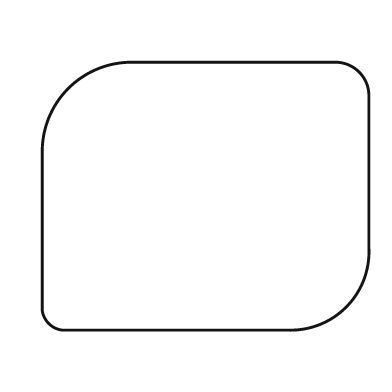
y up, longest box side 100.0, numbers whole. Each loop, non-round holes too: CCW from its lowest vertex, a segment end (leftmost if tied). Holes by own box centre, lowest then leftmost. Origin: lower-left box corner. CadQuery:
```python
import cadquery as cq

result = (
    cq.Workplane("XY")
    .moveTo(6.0, 0.0)
    .lineTo(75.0, 0.0)
    .threePointArc((93.0, 7.0), (100.0, 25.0))
    .lineTo(100.0, 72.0)
    .threePointArc((97.0, 79.0), (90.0, 82.0))
    .lineTo(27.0, 82.0)
    .threePointArc((8.0, 74.0), (0.0, 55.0))
    .lineTo(0.0, 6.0)
    .threePointArc((2.0, 2.0), (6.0, 0.0))
    .close()
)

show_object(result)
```